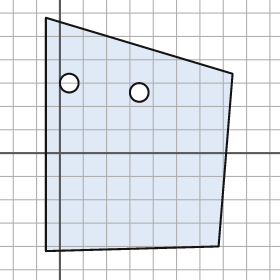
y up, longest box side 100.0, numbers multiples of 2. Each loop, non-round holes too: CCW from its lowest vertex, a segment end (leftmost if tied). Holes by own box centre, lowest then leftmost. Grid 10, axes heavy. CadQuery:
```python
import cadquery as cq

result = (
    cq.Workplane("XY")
    .moveTo(-6.0, -42.0)
    .lineTo(68.0, -40.0)
    .lineTo(74.0, 34.0)
    .lineTo(-6.0, 58.0)
    .close()
    .moveTo(34.0, 26.0)
    .circle(4.0)
    .moveTo(4.0, 30.0)
    .circle(4.0)
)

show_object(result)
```